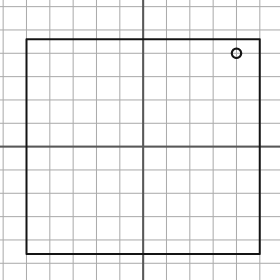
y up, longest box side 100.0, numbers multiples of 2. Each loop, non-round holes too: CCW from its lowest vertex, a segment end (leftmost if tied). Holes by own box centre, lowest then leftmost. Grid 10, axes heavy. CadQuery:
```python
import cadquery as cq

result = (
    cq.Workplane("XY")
    .moveTo(-50.0, -46.0)
    .lineTo(50.0, -46.0)
    .lineTo(50.0, 46.0)
    .lineTo(-50.0, 46.0)
    .close()
    .moveTo(40.0, 40.0)
    .circle(2.0)
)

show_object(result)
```